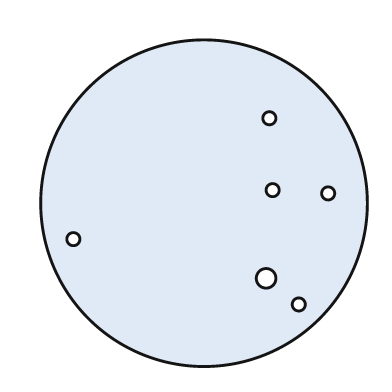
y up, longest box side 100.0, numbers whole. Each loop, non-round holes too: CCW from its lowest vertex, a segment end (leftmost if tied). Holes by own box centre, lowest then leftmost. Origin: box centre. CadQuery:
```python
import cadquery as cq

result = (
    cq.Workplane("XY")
    .moveTo(0.0, 0.0)
    .circle(50.0)
    .moveTo(29.0, -31.0)
    .circle(2.0)
    .moveTo(19.0, -23.0)
    .circle(3.0)
    .moveTo(-40.0, -11.0)
    .circle(2.0)
    .moveTo(38.0, 3.0)
    .circle(2.0)
    .moveTo(21.0, 4.0)
    .circle(2.0)
    .moveTo(20.0, 26.0)
    .circle(2.0)
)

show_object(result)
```